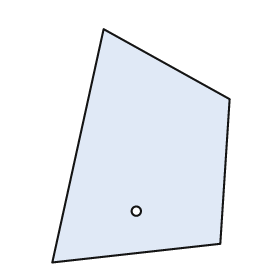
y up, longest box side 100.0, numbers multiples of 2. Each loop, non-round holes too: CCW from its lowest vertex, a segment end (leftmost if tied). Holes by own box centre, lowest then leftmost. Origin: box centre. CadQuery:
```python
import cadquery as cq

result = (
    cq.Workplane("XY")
    .moveTo(-38.0, -50.0)
    .lineTo(34.0, -42.0)
    .lineTo(38.0, 20.0)
    .lineTo(-16.0, 50.0)
    .close()
    .moveTo(-2.0, -28.0)
    .circle(2.0)
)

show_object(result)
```